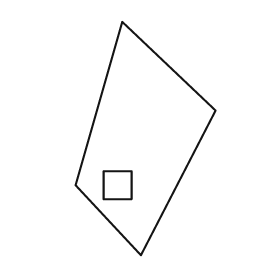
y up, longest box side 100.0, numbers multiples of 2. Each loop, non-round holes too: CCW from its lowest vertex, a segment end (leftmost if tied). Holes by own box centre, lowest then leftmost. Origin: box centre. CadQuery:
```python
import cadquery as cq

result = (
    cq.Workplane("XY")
    .moveTo(-2.0, -50.0)
    .lineTo(30.0, 12.0)
    .lineTo(-10.0, 50.0)
    .lineTo(-30.0, -20.0)
    .close()
    .moveTo(-18.0, -26.0)
    .lineTo(-6.0, -26.0)
    .lineTo(-6.0, -14.0)
    .lineTo(-18.0, -14.0)
    .close()
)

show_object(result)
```